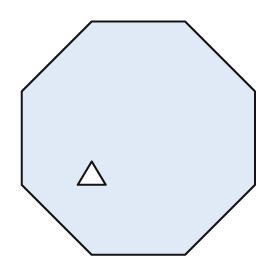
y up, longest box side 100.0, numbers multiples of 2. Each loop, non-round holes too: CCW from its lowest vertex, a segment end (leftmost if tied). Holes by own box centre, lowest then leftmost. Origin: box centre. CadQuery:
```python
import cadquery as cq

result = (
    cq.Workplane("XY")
    .moveTo(-20.0, -50.0)
    .lineTo(20.0, -50.0)
    .lineTo(50.0, -20.0)
    .lineTo(50.0, 20.0)
    .lineTo(20.0, 50.0)
    .lineTo(-20.0, 50.0)
    .lineTo(-50.0, 20.0)
    .lineTo(-50.0, -20.0)
    .close()
    .moveTo(-26.0, -20.0)
    .lineTo(-14.0, -20.0)
    .lineTo(-20.0, -10.0)
    .close()
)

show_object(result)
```